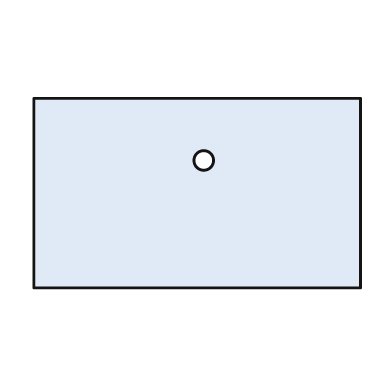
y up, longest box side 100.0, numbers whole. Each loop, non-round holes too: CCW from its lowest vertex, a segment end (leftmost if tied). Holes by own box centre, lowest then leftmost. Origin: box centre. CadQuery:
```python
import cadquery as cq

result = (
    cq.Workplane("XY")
    .moveTo(-50.0, -29.0)
    .lineTo(50.0, -29.0)
    .lineTo(50.0, 29.0)
    .lineTo(-50.0, 29.0)
    .close()
    .moveTo(2.0, 10.0)
    .circle(3.0)
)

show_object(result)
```